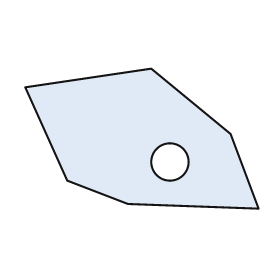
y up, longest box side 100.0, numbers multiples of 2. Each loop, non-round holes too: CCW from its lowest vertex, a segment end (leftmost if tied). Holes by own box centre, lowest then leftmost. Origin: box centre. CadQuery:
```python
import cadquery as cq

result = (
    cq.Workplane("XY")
    .moveTo(50.0, -30.0)
    .lineTo(38.0, 2.0)
    .lineTo(4.0, 30.0)
    .lineTo(-50.0, 22.0)
    .lineTo(-32.0, -18.0)
    .lineTo(-6.0, -28.0)
    .close()
    .moveTo(12.0, -10.0)
    .circle(8.0)
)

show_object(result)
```